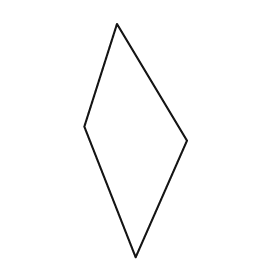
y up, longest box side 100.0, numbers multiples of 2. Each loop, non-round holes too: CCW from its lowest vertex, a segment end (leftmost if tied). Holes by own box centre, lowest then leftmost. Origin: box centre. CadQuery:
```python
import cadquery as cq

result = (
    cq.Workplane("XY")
    .moveTo(0.0, -50.0)
    .lineTo(22.0, 0.0)
    .lineTo(-8.0, 50.0)
    .lineTo(-22.0, 6.0)
    .close()
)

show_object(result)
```